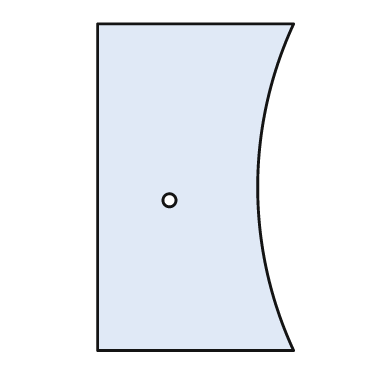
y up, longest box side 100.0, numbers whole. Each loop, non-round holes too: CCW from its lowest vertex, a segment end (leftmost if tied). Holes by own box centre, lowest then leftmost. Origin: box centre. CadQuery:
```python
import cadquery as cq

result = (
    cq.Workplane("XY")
    .moveTo(-30.0, -50.0)
    .lineTo(30.0, -50.0)
    .threePointArc((19.0, 0.0), (30.0, 50.0))
    .lineTo(-30.0, 50.0)
    .close()
    .moveTo(-8.0, -4.0)
    .circle(2.0)
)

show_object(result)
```